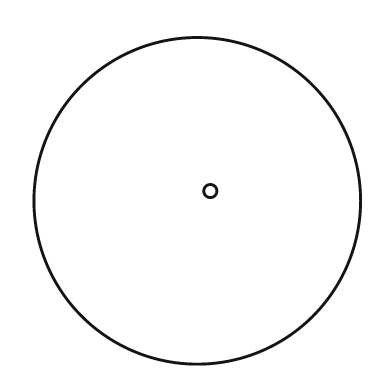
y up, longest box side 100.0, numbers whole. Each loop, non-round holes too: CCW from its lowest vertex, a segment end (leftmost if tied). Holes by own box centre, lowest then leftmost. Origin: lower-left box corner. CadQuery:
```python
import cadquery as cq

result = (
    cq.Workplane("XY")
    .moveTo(50.0, 50.0)
    .circle(50.0)
    .moveTo(54.0, 53.0)
    .circle(2.0)
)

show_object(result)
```